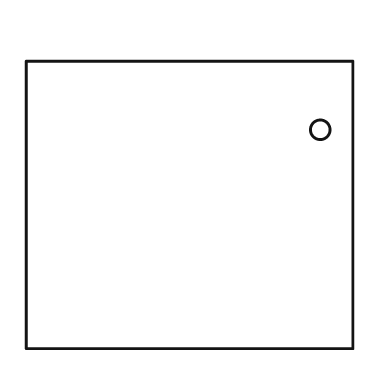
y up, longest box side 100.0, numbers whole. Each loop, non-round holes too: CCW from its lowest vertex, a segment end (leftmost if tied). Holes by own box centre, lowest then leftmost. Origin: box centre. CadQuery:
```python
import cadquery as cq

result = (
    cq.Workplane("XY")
    .moveTo(-50.0, -44.0)
    .lineTo(50.0, -44.0)
    .lineTo(50.0, 44.0)
    .lineTo(-50.0, 44.0)
    .close()
    .moveTo(40.0, 23.0)
    .circle(3.0)
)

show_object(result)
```